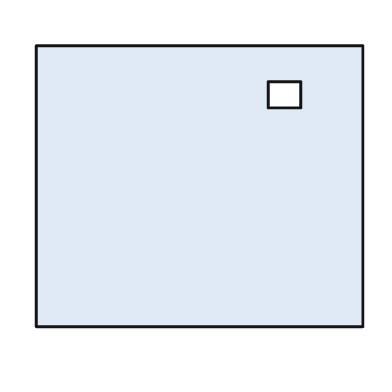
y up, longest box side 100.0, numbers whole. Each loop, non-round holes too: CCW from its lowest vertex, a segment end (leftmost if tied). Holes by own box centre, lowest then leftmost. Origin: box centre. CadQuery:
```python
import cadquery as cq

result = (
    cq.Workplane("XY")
    .moveTo(-50.0, -43.0)
    .lineTo(50.0, -43.0)
    .lineTo(50.0, 43.0)
    .lineTo(-50.0, 43.0)
    .close()
    .moveTo(21.0, 24.0)
    .lineTo(31.0, 24.0)
    .lineTo(31.0, 32.0)
    .lineTo(21.0, 32.0)
    .close()
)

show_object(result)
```